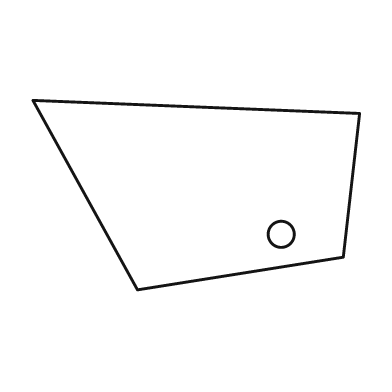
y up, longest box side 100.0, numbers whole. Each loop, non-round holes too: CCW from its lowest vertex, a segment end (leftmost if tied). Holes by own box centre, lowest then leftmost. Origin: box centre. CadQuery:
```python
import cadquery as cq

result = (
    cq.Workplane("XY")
    .moveTo(-18.0, -29.0)
    .lineTo(45.0, -19.0)
    .lineTo(50.0, 25.0)
    .lineTo(-50.0, 29.0)
    .close()
    .moveTo(26.0, -12.0)
    .circle(4.0)
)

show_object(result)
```